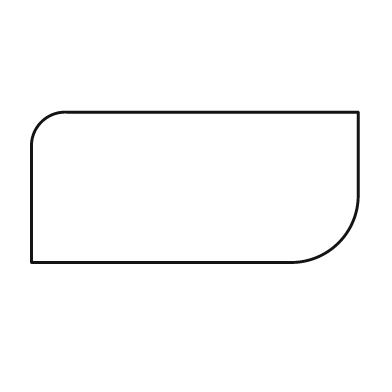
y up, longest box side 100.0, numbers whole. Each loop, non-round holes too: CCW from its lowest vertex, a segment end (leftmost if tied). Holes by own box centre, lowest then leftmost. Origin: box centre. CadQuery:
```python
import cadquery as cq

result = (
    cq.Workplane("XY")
    .moveTo(-50.0, -23.0)
    .lineTo(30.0, -23.0)
    .threePointArc((44.0, -17.0), (50.0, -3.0))
    .lineTo(50.0, 23.0)
    .lineTo(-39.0, 23.0)
    .threePointArc((-47.0, 20.0), (-50.0, 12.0))
    .close()
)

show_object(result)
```